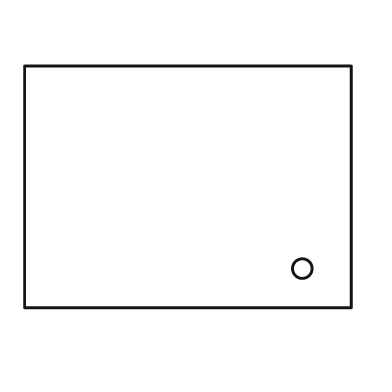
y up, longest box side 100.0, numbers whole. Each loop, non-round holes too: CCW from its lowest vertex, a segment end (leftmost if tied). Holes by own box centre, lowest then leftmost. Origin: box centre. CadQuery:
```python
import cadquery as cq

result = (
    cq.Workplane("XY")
    .moveTo(-50.0, -37.0)
    .lineTo(50.0, -37.0)
    .lineTo(50.0, 37.0)
    .lineTo(-50.0, 37.0)
    .close()
    .moveTo(35.0, -25.0)
    .circle(3.0)
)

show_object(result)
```